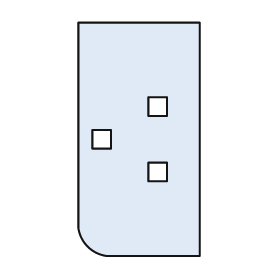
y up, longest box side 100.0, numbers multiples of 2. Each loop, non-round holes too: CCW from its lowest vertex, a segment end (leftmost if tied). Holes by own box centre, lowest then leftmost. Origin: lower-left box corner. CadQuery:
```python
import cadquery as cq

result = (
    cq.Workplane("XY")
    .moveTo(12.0, 0.0)
    .lineTo(52.0, 0.0)
    .lineTo(52.0, 100.0)
    .lineTo(0.0, 100.0)
    .lineTo(0.0, 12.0)
    .threePointArc((4.0, 4.0), (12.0, 0.0))
    .close()
    .moveTo(30.0, 32.0)
    .lineTo(38.0, 32.0)
    .lineTo(38.0, 40.0)
    .lineTo(30.0, 40.0)
    .close()
    .moveTo(6.0, 46.0)
    .lineTo(14.0, 46.0)
    .lineTo(14.0, 54.0)
    .lineTo(6.0, 54.0)
    .close()
    .moveTo(30.0, 60.0)
    .lineTo(38.0, 60.0)
    .lineTo(38.0, 68.0)
    .lineTo(30.0, 68.0)
    .close()
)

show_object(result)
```